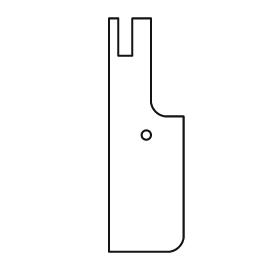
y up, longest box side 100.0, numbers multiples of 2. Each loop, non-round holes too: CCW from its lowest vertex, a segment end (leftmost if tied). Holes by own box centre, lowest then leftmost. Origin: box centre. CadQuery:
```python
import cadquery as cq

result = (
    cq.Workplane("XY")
    .moveTo(-16.0, -50.0)
    .lineTo(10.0, -50.0)
    .threePointArc((14.0, -48.0), (16.0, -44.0))
    .lineTo(16.0, 8.0)
    .lineTo(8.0, 8.0)
    .threePointArc((4.0, 10.0), (2.0, 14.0))
    .lineTo(2.0, 50.0)
    .lineTo(-6.0, 50.0)
    .lineTo(-6.0, 34.0)
    .lineTo(-12.0, 34.0)
    .lineTo(-12.0, 50.0)
    .lineTo(-16.0, 50.0)
    .close()
    .moveTo(0.0, 0.0)
    .circle(2.0)
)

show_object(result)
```